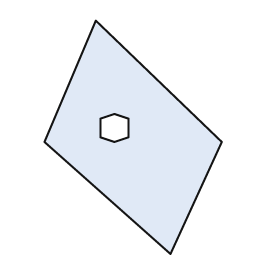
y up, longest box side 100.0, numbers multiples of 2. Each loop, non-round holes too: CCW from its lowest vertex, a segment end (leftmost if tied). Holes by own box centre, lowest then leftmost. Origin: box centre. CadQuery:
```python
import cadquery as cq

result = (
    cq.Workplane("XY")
    .moveTo(16.0, -50.0)
    .lineTo(38.0, -2.0)
    .lineTo(-16.0, 50.0)
    .lineTo(-38.0, -2.0)
    .close()
    .moveTo(-8.0, -2.0)
    .lineTo(-2.0, 0.0)
    .lineTo(-2.0, 8.0)
    .lineTo(-8.0, 10.0)
    .lineTo(-14.0, 8.0)
    .lineTo(-14.0, 0.0)
    .close()
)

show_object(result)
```